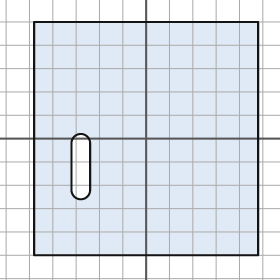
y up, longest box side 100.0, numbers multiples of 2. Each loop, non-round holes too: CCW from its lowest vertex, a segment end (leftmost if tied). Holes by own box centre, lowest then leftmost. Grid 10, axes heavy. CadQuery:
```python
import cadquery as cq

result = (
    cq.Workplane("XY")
    .moveTo(-48.0, -50.0)
    .lineTo(48.0, -50.0)
    .lineTo(48.0, 50.0)
    .lineTo(-48.0, 50.0)
    .close()
    .moveTo(-32.0, -22.0)
    .threePointArc((-28.0, -26.0), (-24.0, -22.0))
    .lineTo(-24.0, -2.0)
    .threePointArc((-28.0, 2.0), (-32.0, -2.0))
    .close()
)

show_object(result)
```